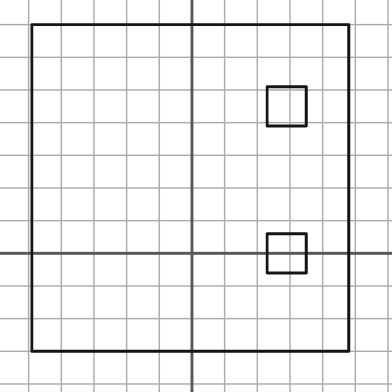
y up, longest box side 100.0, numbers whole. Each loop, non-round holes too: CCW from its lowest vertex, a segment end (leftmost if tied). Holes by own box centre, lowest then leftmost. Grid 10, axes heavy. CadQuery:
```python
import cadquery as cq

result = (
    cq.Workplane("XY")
    .moveTo(-49.0, -30.0)
    .lineTo(48.0, -30.0)
    .lineTo(48.0, 70.0)
    .lineTo(-49.0, 70.0)
    .close()
    .moveTo(23.0, -6.0)
    .lineTo(35.0, -6.0)
    .lineTo(35.0, 6.0)
    .lineTo(23.0, 6.0)
    .close()
    .moveTo(23.0, 39.0)
    .lineTo(35.0, 39.0)
    .lineTo(35.0, 51.0)
    .lineTo(23.0, 51.0)
    .close()
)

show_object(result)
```